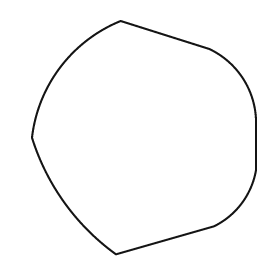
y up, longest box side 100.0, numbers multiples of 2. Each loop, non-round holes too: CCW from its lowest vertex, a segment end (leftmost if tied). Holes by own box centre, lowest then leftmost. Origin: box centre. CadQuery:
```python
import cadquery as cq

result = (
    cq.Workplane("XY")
    .moveTo(-12.0, -50.0)
    .lineTo(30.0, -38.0)
    .threePointArc((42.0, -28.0), (48.0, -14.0))
    .lineTo(48.0, 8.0)
    .threePointArc((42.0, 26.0), (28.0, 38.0))
    .lineTo(-10.0, 50.0)
    .threePointArc((-36.0, 30.0), (-48.0, 0.0))
    .threePointArc((-34.0, -28.0), (-12.0, -50.0))
    .close()
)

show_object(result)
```